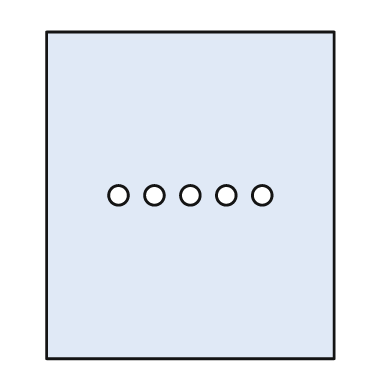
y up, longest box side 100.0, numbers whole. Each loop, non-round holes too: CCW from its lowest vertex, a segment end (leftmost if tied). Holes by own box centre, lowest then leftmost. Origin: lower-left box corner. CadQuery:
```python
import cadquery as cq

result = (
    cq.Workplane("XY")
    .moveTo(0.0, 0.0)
    .lineTo(88.0, 0.0)
    .lineTo(88.0, 100.0)
    .lineTo(0.0, 100.0)
    .close()
    .moveTo(22.0, 50.0)
    .circle(3.0)
    .moveTo(33.0, 50.0)
    .circle(3.0)
    .moveTo(44.0, 50.0)
    .circle(3.0)
    .moveTo(55.0, 50.0)
    .circle(3.0)
    .moveTo(66.0, 50.0)
    .circle(3.0)
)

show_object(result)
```